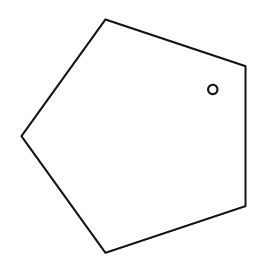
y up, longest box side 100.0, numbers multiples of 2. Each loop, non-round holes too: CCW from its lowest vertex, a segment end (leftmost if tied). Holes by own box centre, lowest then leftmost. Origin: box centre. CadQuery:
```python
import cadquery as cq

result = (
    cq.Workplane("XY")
    .moveTo(-12.0, -50.0)
    .lineTo(48.0, -30.0)
    .lineTo(48.0, 30.0)
    .lineTo(-12.0, 50.0)
    .lineTo(-48.0, 0.0)
    .close()
    .moveTo(34.0, 20.0)
    .circle(2.0)
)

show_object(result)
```